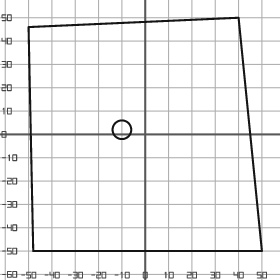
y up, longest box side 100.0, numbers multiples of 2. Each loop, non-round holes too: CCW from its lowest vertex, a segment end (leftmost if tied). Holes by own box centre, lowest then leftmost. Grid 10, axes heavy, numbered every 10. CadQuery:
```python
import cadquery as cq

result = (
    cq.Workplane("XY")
    .moveTo(-48.0, -50.0)
    .lineTo(50.0, -50.0)
    .lineTo(40.0, 50.0)
    .lineTo(-50.0, 46.0)
    .close()
    .moveTo(-10.0, 2.0)
    .circle(4.0)
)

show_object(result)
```